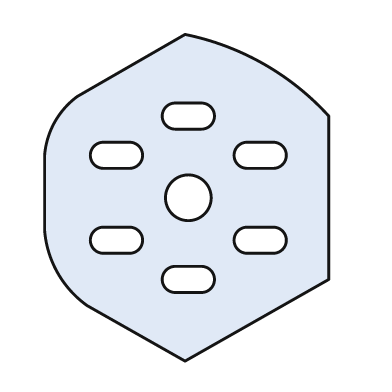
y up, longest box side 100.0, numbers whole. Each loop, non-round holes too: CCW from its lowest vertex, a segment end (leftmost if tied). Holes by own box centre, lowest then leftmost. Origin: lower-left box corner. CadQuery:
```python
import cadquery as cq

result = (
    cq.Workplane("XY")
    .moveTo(43.0, 0.0)
    .lineTo(87.0, 25.0)
    .lineTo(87.0, 75.0)
    .threePointArc((67.0, 91.0), (43.0, 100.0))
    .lineTo(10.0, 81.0)
    .threePointArc((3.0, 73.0), (0.0, 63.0))
    .lineTo(0.0, 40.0)
    .threePointArc((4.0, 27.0), (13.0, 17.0))
    .close()
    .moveTo(40.0, 21.0)
    .lineTo(48.0, 21.0)
    .threePointArc((52.0, 25.0), (48.0, 29.0))
    .lineTo(40.0, 29.0)
    .threePointArc((36.0, 25.0), (40.0, 21.0))
    .close()
    .moveTo(18.0, 33.0)
    .lineTo(26.0, 33.0)
    .threePointArc((30.0, 37.0), (26.0, 41.0))
    .lineTo(18.0, 41.0)
    .threePointArc((14.0, 37.0), (18.0, 33.0))
    .close()
    .moveTo(62.0, 33.0)
    .lineTo(70.0, 33.0)
    .threePointArc((74.0, 37.0), (70.0, 41.0))
    .lineTo(62.0, 41.0)
    .threePointArc((58.0, 37.0), (62.0, 33.0))
    .close()
    .moveTo(44.0, 50.0)
    .circle(7.0)
    .moveTo(18.0, 59.0)
    .lineTo(26.0, 59.0)
    .threePointArc((30.0, 63.0), (26.0, 67.0))
    .lineTo(18.0, 67.0)
    .threePointArc((14.0, 63.0), (18.0, 59.0))
    .close()
    .moveTo(62.0, 59.0)
    .lineTo(70.0, 59.0)
    .threePointArc((74.0, 63.0), (70.0, 67.0))
    .lineTo(62.0, 67.0)
    .threePointArc((58.0, 63.0), (62.0, 59.0))
    .close()
    .moveTo(40.0, 71.0)
    .lineTo(48.0, 71.0)
    .threePointArc((52.0, 75.0), (48.0, 79.0))
    .lineTo(40.0, 79.0)
    .threePointArc((36.0, 75.0), (40.0, 71.0))
    .close()
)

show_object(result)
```